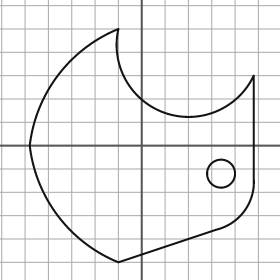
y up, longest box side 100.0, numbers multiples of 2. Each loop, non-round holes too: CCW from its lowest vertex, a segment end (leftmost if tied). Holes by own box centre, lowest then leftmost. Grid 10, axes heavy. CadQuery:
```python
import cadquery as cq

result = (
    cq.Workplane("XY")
    .moveTo(-10.0, -50.0)
    .lineTo(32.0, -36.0)
    .threePointArc((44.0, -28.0), (48.0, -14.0))
    .lineTo(48.0, 30.0)
    .threePointArc((10.0, 14.0), (-10.0, 50.0))
    .threePointArc((-36.0, 30.0), (-48.0, 0.0))
    .threePointArc((-36.0, -30.0), (-10.0, -50.0))
    .close()
    .moveTo(34.0, -12.0)
    .circle(6.0)
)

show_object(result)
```